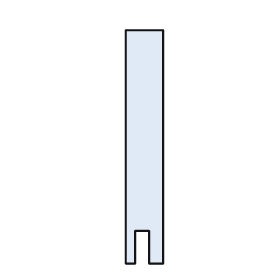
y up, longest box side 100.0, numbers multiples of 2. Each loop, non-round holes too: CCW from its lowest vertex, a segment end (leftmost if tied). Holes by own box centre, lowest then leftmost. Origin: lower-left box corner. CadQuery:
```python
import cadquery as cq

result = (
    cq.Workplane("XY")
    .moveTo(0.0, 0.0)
    .lineTo(4.0, 0.0)
    .lineTo(4.0, 14.0)
    .lineTo(10.0, 14.0)
    .lineTo(10.0, 0.0)
    .lineTo(16.0, 0.0)
    .lineTo(16.0, 100.0)
    .lineTo(0.0, 100.0)
    .close()
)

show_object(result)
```